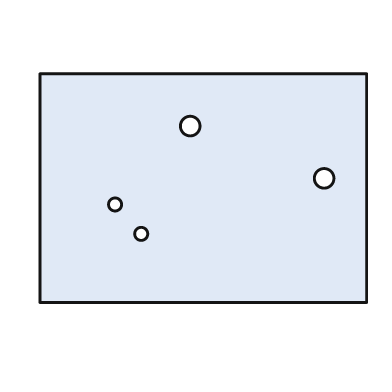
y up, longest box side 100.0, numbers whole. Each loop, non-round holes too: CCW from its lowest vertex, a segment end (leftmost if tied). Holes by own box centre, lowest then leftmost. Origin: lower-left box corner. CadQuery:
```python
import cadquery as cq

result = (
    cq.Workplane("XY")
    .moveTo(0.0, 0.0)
    .lineTo(100.0, 0.0)
    .lineTo(100.0, 70.0)
    .lineTo(0.0, 70.0)
    .close()
    .moveTo(31.0, 21.0)
    .circle(2.0)
    .moveTo(23.0, 30.0)
    .circle(2.0)
    .moveTo(87.0, 38.0)
    .circle(3.0)
    .moveTo(46.0, 54.0)
    .circle(3.0)
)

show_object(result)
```